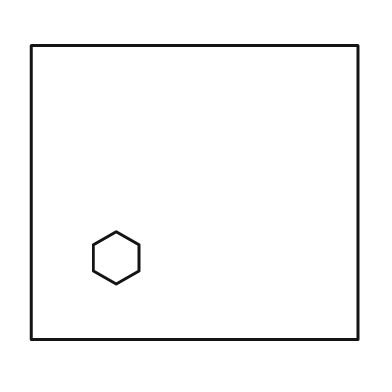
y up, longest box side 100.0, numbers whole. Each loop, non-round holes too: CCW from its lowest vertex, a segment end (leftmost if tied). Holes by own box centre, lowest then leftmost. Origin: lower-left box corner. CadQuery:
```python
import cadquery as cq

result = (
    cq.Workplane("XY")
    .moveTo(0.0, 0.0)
    .lineTo(100.0, 0.0)
    .lineTo(100.0, 90.0)
    .lineTo(0.0, 90.0)
    .close()
    .moveTo(26.0, 17.0)
    .lineTo(33.0, 21.0)
    .lineTo(33.0, 29.0)
    .lineTo(26.0, 33.0)
    .lineTo(19.0, 29.0)
    .lineTo(19.0, 21.0)
    .close()
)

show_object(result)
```